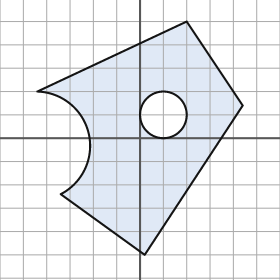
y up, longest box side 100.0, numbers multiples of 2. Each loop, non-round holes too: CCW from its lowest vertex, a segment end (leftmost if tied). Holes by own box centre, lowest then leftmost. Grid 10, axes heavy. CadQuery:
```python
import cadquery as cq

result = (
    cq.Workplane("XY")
    .moveTo(2.0, -50.0)
    .lineTo(44.0, 14.0)
    .lineTo(20.0, 50.0)
    .lineTo(-44.0, 20.0)
    .threePointArc((-22.0, 2.0), (-34.0, -24.0))
    .close()
    .moveTo(10.0, 10.0)
    .circle(10.0)
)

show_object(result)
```